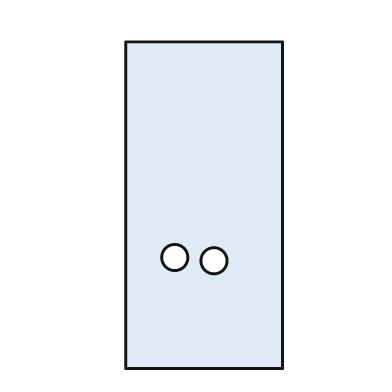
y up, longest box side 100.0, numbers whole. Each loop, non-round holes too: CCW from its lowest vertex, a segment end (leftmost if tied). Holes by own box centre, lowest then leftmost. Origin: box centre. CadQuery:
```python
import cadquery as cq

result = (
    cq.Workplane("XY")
    .moveTo(-24.0, -50.0)
    .lineTo(24.0, -50.0)
    .lineTo(24.0, 50.0)
    .lineTo(-24.0, 50.0)
    .close()
    .moveTo(3.0, -17.0)
    .circle(4.0)
    .moveTo(-9.0, -16.0)
    .circle(4.0)
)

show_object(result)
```